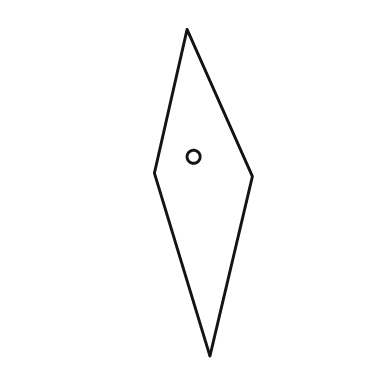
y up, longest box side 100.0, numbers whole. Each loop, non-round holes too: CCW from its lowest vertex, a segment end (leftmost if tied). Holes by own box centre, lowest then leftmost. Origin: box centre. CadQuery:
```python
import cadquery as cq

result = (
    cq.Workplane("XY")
    .moveTo(2.0, -50.0)
    .lineTo(15.0, 5.0)
    .lineTo(-5.0, 50.0)
    .lineTo(-15.0, 6.0)
    .close()
    .moveTo(-3.0, 11.0)
    .circle(2.0)
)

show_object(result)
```